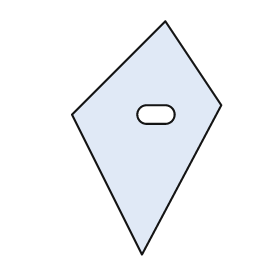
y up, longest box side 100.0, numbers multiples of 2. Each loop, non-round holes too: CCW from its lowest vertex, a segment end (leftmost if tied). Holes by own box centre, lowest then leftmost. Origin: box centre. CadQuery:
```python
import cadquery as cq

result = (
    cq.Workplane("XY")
    .moveTo(-2.0, -50.0)
    .lineTo(32.0, 14.0)
    .lineTo(8.0, 50.0)
    .lineTo(-32.0, 10.0)
    .close()
    .moveTo(0.0, 6.0)
    .lineTo(8.0, 6.0)
    .threePointArc((12.0, 10.0), (8.0, 14.0))
    .lineTo(0.0, 14.0)
    .threePointArc((-4.0, 10.0), (0.0, 6.0))
    .close()
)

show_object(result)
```